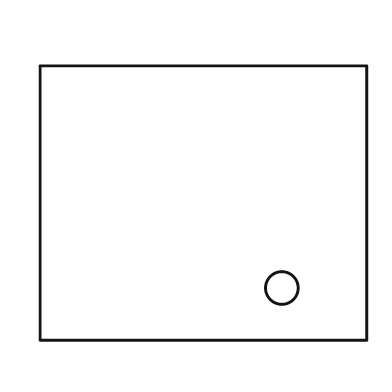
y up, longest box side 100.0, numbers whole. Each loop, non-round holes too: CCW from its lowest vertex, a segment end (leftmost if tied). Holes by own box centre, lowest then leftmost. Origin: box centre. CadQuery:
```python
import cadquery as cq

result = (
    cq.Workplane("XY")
    .moveTo(-50.0, -42.0)
    .lineTo(50.0, -42.0)
    .lineTo(50.0, 42.0)
    .lineTo(-50.0, 42.0)
    .close()
    .moveTo(24.0, -26.0)
    .circle(5.0)
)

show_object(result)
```